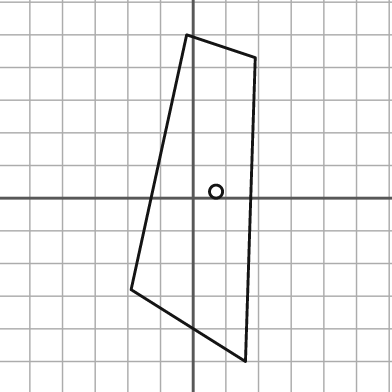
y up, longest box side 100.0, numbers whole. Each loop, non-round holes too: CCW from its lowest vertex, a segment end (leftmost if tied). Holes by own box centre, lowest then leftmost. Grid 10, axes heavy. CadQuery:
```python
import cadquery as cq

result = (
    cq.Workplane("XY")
    .moveTo(16.0, -50.0)
    .lineTo(19.0, 43.0)
    .lineTo(-2.0, 50.0)
    .lineTo(-19.0, -28.0)
    .close()
    .moveTo(7.0, 2.0)
    .circle(2.0)
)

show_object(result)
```